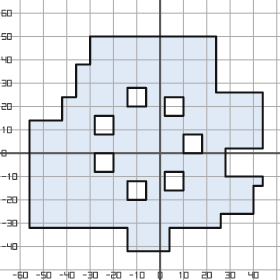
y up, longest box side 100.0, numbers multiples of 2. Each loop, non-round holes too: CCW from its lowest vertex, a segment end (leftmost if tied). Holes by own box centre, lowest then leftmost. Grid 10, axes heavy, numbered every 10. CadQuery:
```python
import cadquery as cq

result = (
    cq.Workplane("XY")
    .moveTo(-14.0, -42.0)
    .lineTo(4.0, -42.0)
    .lineTo(4.0, -32.0)
    .lineTo(26.0, -32.0)
    .lineTo(26.0, -26.0)
    .lineTo(40.0, -26.0)
    .lineTo(40.0, -14.0)
    .lineTo(44.0, -14.0)
    .lineTo(44.0, -10.0)
    .lineTo(28.0, -10.0)
    .lineTo(28.0, 2.0)
    .lineTo(44.0, 2.0)
    .lineTo(44.0, 26.0)
    .lineTo(24.0, 26.0)
    .lineTo(24.0, 50.0)
    .lineTo(-30.0, 50.0)
    .lineTo(-30.0, 38.0)
    .lineTo(-36.0, 38.0)
    .lineTo(-36.0, 24.0)
    .lineTo(-42.0, 24.0)
    .lineTo(-42.0, 14.0)
    .lineTo(-56.0, 14.0)
    .lineTo(-56.0, -32.0)
    .lineTo(-14.0, -32.0)
    .close()
    .moveTo(-14.0, -20.0)
    .lineTo(-6.0, -20.0)
    .lineTo(-6.0, -12.0)
    .lineTo(-14.0, -12.0)
    .close()
    .moveTo(2.0, -16.0)
    .lineTo(10.0, -16.0)
    .lineTo(10.0, -8.0)
    .lineTo(2.0, -8.0)
    .close()
    .moveTo(-28.0, -8.0)
    .lineTo(-20.0, -8.0)
    .lineTo(-20.0, 0.0)
    .lineTo(-28.0, 0.0)
    .close()
    .moveTo(10.0, 0.0)
    .lineTo(18.0, 0.0)
    .lineTo(18.0, 8.0)
    .lineTo(10.0, 8.0)
    .close()
    .moveTo(-28.0, 8.0)
    .lineTo(-20.0, 8.0)
    .lineTo(-20.0, 16.0)
    .lineTo(-28.0, 16.0)
    .close()
    .moveTo(2.0, 16.0)
    .lineTo(10.0, 16.0)
    .lineTo(10.0, 24.0)
    .lineTo(2.0, 24.0)
    .close()
    .moveTo(-14.0, 20.0)
    .lineTo(-6.0, 20.0)
    .lineTo(-6.0, 28.0)
    .lineTo(-14.0, 28.0)
    .close()
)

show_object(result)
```